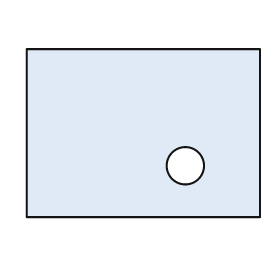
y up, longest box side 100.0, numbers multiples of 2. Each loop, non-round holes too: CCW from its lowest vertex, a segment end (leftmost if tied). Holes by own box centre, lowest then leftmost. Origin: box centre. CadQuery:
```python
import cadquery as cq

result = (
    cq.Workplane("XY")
    .moveTo(-50.0, -36.0)
    .lineTo(50.0, -36.0)
    .lineTo(50.0, 36.0)
    .lineTo(-50.0, 36.0)
    .close()
    .moveTo(18.0, -14.0)
    .circle(8.0)
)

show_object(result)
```